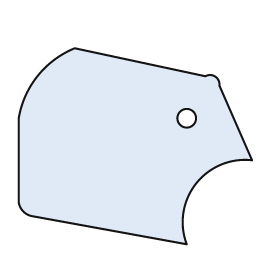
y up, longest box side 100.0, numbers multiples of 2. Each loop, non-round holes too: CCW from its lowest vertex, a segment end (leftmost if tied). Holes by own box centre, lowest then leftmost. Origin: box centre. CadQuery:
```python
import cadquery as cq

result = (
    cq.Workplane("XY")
    .moveTo(22.0, -42.0)
    .threePointArc((26.0, -16.0), (50.0, -6.0))
    .lineTo(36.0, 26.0)
    .threePointArc((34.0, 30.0), (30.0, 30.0))
    .lineTo(-26.0, 42.0)
    .threePointArc((-42.0, 30.0), (-50.0, 12.0))
    .lineTo(-50.0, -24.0)
    .threePointArc((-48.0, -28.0), (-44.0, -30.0))
    .close()
    .moveTo(22.0, 12.0)
    .circle(4.0)
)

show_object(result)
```